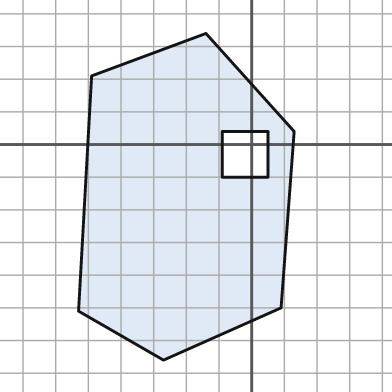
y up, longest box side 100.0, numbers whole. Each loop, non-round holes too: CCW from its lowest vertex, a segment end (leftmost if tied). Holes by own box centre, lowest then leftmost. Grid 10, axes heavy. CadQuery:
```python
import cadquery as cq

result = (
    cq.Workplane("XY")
    .moveTo(-27.0, -66.0)
    .lineTo(9.0, -50.0)
    .lineTo(13.0, 4.0)
    .lineTo(-14.0, 34.0)
    .lineTo(-49.0, 21.0)
    .lineTo(-53.0, -51.0)
    .close()
    .moveTo(-9.0, -10.0)
    .lineTo(5.0, -10.0)
    .lineTo(5.0, 4.0)
    .lineTo(-9.0, 4.0)
    .close()
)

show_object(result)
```